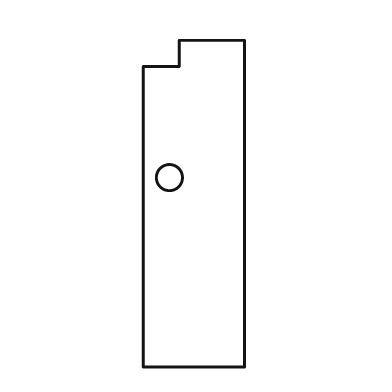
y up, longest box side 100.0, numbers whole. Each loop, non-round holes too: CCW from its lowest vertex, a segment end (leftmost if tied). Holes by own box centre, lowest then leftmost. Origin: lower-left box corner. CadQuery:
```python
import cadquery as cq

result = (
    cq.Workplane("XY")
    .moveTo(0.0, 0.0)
    .lineTo(31.0, 0.0)
    .lineTo(31.0, 100.0)
    .lineTo(11.0, 100.0)
    .lineTo(11.0, 92.0)
    .lineTo(0.0, 92.0)
    .close()
    .moveTo(8.0, 58.0)
    .circle(4.0)
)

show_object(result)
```